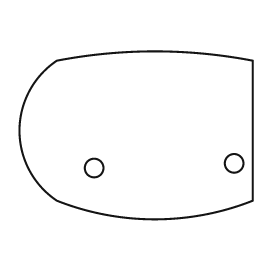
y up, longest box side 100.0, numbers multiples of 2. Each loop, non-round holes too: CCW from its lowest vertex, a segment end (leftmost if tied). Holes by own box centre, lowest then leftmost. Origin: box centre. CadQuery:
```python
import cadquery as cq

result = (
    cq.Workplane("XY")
    .moveTo(-34.0, -28.0)
    .threePointArc((8.0, -36.0), (50.0, -28.0))
    .lineTo(50.0, 32.0)
    .threePointArc((8.0, 36.0), (-34.0, 32.0))
    .threePointArc((-50.0, 2.0), (-34.0, -28.0))
    .close()
    .moveTo(-18.0, -14.0)
    .circle(4.0)
    .moveTo(42.0, -12.0)
    .circle(4.0)
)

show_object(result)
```